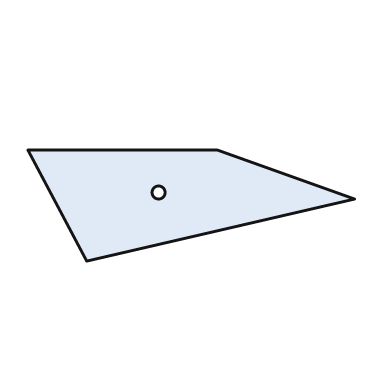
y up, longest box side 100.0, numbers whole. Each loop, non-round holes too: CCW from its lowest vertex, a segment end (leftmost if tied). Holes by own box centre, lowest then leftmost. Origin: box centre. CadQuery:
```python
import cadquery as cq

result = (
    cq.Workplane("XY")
    .moveTo(-32.0, -17.0)
    .lineTo(50.0, 2.0)
    .lineTo(8.0, 17.0)
    .lineTo(-50.0, 17.0)
    .close()
    .moveTo(-10.0, 4.0)
    .circle(2.0)
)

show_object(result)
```